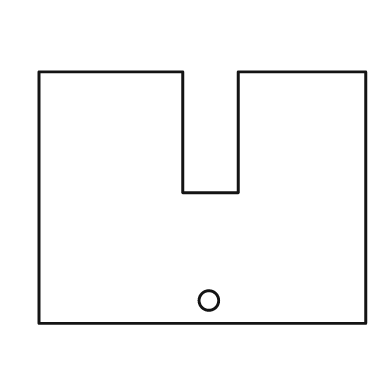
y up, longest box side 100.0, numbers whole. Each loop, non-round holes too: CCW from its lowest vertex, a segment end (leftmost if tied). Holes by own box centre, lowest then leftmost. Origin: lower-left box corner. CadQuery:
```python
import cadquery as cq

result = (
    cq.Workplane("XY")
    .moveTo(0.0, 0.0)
    .lineTo(100.0, 0.0)
    .lineTo(100.0, 77.0)
    .lineTo(61.0, 77.0)
    .lineTo(61.0, 40.0)
    .lineTo(44.0, 40.0)
    .lineTo(44.0, 77.0)
    .lineTo(0.0, 77.0)
    .close()
    .moveTo(52.0, 7.0)
    .circle(3.0)
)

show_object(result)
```